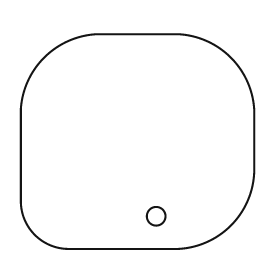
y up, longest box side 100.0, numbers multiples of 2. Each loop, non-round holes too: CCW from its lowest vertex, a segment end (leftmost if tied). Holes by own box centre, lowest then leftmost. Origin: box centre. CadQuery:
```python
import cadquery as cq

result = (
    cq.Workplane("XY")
    .moveTo(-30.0, -46.0)
    .lineTo(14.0, -46.0)
    .threePointArc((40.0, -36.0), (50.0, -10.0))
    .lineTo(50.0, 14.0)
    .threePointArc((40.0, 36.0), (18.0, 46.0))
    .lineTo(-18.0, 46.0)
    .threePointArc((-40.0, 36.0), (-50.0, 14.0))
    .lineTo(-50.0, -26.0)
    .threePointArc((-44.0, -40.0), (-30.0, -46.0))
    .close()
    .moveTo(8.0, -32.0)
    .circle(4.0)
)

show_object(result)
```